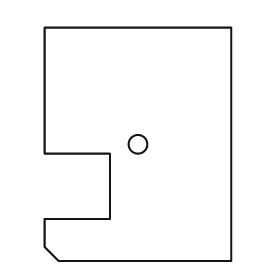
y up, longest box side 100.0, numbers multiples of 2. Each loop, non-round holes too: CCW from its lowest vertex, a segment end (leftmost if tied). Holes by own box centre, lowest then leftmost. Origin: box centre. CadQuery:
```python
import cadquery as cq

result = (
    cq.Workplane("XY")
    .moveTo(-34.0, -50.0)
    .lineTo(40.0, -50.0)
    .lineTo(40.0, 50.0)
    .lineTo(-40.0, 50.0)
    .lineTo(-40.0, -4.0)
    .lineTo(-12.0, -4.0)
    .lineTo(-12.0, -32.0)
    .lineTo(-40.0, -32.0)
    .lineTo(-40.0, -44.0)
    .close()
    .moveTo(0.0, 0.0)
    .circle(4.0)
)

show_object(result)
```